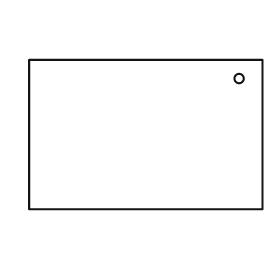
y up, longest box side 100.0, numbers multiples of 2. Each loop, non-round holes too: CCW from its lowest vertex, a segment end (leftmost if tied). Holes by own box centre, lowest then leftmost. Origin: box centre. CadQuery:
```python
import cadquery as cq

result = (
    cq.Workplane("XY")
    .moveTo(-50.0, -32.0)
    .lineTo(50.0, -32.0)
    .lineTo(50.0, 32.0)
    .lineTo(-50.0, 32.0)
    .close()
    .moveTo(40.0, 24.0)
    .circle(2.0)
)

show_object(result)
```